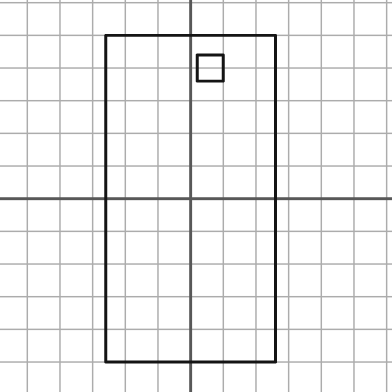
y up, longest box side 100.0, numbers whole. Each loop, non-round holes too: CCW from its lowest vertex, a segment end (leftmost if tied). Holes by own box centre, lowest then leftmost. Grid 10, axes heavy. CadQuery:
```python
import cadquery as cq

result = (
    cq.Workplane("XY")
    .moveTo(-26.0, -50.0)
    .lineTo(26.0, -50.0)
    .lineTo(26.0, 50.0)
    .lineTo(-26.0, 50.0)
    .close()
    .moveTo(2.0, 36.0)
    .lineTo(10.0, 36.0)
    .lineTo(10.0, 44.0)
    .lineTo(2.0, 44.0)
    .close()
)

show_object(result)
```